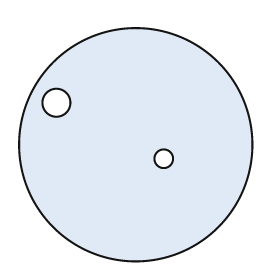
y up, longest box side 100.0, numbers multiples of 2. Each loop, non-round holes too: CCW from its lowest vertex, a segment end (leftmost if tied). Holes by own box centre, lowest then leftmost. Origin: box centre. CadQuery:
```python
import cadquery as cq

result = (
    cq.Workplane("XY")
    .moveTo(0.0, 0.0)
    .circle(50.0)
    .moveTo(12.0, -6.0)
    .circle(4.0)
    .moveTo(-34.0, 18.0)
    .circle(6.0)
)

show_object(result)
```